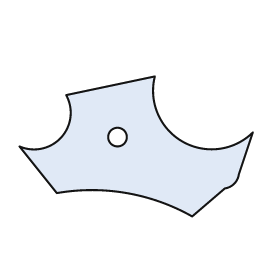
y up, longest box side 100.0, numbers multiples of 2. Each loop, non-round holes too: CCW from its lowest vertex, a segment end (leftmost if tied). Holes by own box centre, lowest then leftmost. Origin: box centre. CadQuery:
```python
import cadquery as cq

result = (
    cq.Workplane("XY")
    .moveTo(24.0, -30.0)
    .lineTo(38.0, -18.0)
    .threePointArc((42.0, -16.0), (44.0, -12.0))
    .lineTo(50.0, 6.0)
    .threePointArc((20.0, 2.0), (8.0, 30.0))
    .lineTo(-30.0, 22.0)
    .threePointArc((-32.0, 4.0), (-50.0, 0.0))
    .lineTo(-34.0, -20.0)
    .threePointArc((-4.0, -20.0), (24.0, -30.0))
    .close()
    .moveTo(-8.0, 4.0)
    .circle(4.0)
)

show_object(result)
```